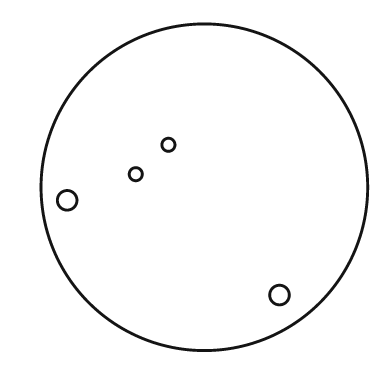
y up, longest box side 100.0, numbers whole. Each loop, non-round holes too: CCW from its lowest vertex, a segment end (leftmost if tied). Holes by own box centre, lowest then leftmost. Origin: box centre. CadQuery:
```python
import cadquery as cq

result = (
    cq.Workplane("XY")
    .moveTo(0.0, 0.0)
    .circle(50.0)
    .moveTo(23.0, -33.0)
    .circle(3.0)
    .moveTo(-42.0, -4.0)
    .circle(3.0)
    .moveTo(-21.0, 4.0)
    .circle(2.0)
    .moveTo(-11.0, 13.0)
    .circle(2.0)
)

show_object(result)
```